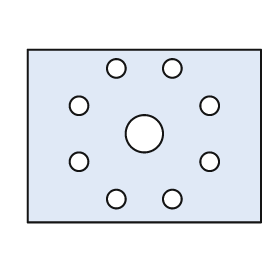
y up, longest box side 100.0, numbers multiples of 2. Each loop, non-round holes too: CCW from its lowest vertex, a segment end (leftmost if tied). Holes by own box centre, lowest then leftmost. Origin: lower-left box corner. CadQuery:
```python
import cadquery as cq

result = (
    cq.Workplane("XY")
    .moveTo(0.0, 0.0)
    .lineTo(100.0, 0.0)
    .lineTo(100.0, 74.0)
    .lineTo(0.0, 74.0)
    .close()
    .moveTo(38.0, 10.0)
    .circle(4.0)
    .moveTo(62.0, 10.0)
    .circle(4.0)
    .moveTo(22.0, 26.0)
    .circle(4.0)
    .moveTo(78.0, 26.0)
    .circle(4.0)
    .moveTo(50.0, 38.0)
    .circle(8.0)
    .moveTo(22.0, 50.0)
    .circle(4.0)
    .moveTo(78.0, 50.0)
    .circle(4.0)
    .moveTo(38.0, 66.0)
    .circle(4.0)
    .moveTo(62.0, 66.0)
    .circle(4.0)
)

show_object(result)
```